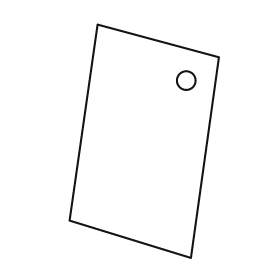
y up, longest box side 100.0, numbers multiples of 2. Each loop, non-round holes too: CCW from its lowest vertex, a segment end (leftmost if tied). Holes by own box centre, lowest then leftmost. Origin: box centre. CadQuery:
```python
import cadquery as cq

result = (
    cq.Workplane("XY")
    .moveTo(20.0, -50.0)
    .lineTo(32.0, 36.0)
    .lineTo(-20.0, 50.0)
    .lineTo(-32.0, -34.0)
    .close()
    .moveTo(18.0, 26.0)
    .circle(4.0)
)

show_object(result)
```